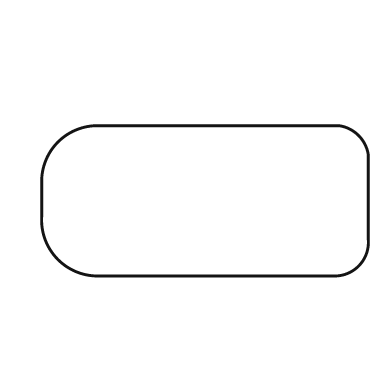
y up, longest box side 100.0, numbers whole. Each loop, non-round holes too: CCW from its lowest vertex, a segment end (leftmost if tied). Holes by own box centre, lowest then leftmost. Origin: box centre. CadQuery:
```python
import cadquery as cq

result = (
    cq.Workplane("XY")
    .moveTo(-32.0, -23.0)
    .lineTo(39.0, -23.0)
    .threePointArc((47.0, -20.0), (50.0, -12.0))
    .lineTo(50.0, 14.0)
    .threePointArc((47.0, 20.0), (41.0, 23.0))
    .lineTo(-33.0, 23.0)
    .threePointArc((-45.0, 18.0), (-50.0, 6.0))
    .lineTo(-50.0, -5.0)
    .threePointArc((-45.0, -18.0), (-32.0, -23.0))
    .close()
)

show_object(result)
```